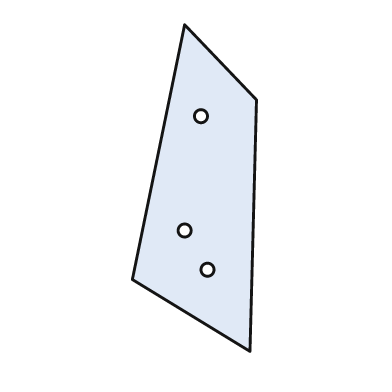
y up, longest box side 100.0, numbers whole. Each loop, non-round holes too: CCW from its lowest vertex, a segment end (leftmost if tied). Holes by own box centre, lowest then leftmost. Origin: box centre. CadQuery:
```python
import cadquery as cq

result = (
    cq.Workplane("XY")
    .moveTo(17.0, -50.0)
    .lineTo(19.0, 27.0)
    .lineTo(-3.0, 50.0)
    .lineTo(-19.0, -28.0)
    .close()
    .moveTo(4.0, -25.0)
    .circle(2.0)
    .moveTo(-3.0, -13.0)
    .circle(2.0)
    .moveTo(2.0, 22.0)
    .circle(2.0)
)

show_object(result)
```